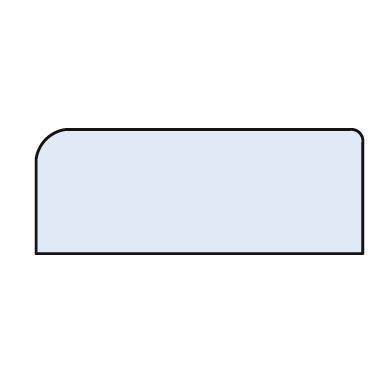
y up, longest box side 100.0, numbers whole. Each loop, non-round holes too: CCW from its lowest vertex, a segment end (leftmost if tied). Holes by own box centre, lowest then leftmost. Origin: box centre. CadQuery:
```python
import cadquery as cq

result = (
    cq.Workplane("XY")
    .moveTo(-50.0, -19.0)
    .lineTo(50.0, -19.0)
    .lineTo(50.0, 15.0)
    .threePointArc((49.0, 18.0), (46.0, 19.0))
    .lineTo(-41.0, 19.0)
    .threePointArc((-47.0, 16.0), (-50.0, 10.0))
    .close()
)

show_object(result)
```